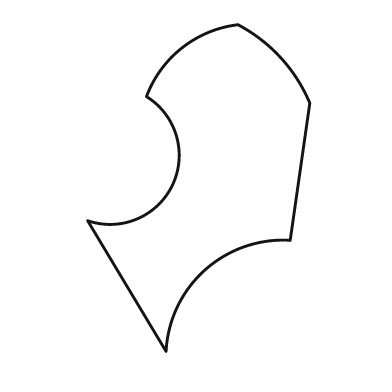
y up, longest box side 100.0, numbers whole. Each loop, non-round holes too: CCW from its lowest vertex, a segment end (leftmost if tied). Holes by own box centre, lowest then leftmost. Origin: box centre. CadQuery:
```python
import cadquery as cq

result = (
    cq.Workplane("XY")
    .moveTo(-10.0, -50.0)
    .threePointArc((2.0, -25.0), (28.0, -16.0))
    .lineTo(34.0, 26.0)
    .threePointArc((25.0, 40.0), (12.0, 50.0))
    .threePointArc((-5.0, 43.0), (-16.0, 28.0))
    .threePointArc((-8.0, 1.0), (-34.0, -10.0))
    .close()
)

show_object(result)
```